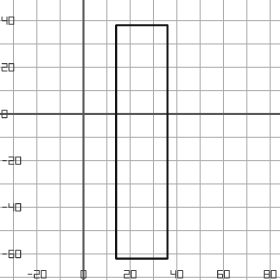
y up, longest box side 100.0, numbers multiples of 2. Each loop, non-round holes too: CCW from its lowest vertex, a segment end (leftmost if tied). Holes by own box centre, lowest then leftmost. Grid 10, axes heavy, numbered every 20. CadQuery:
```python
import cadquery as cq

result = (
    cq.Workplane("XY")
    .moveTo(14.0, -62.0)
    .lineTo(36.0, -62.0)
    .lineTo(36.0, 38.0)
    .lineTo(14.0, 38.0)
    .close()
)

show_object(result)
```